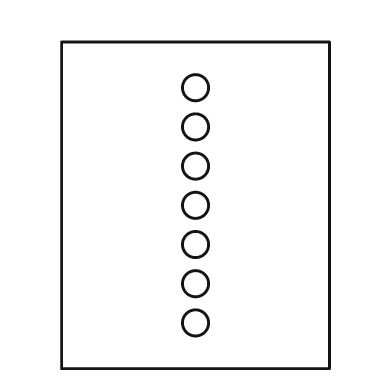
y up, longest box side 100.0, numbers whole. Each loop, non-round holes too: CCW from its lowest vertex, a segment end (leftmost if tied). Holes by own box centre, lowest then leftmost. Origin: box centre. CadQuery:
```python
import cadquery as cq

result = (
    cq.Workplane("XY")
    .moveTo(-41.0, -50.0)
    .lineTo(41.0, -50.0)
    .lineTo(41.0, 50.0)
    .lineTo(-41.0, 50.0)
    .close()
    .moveTo(0.0, -36.0)
    .circle(4.0)
    .moveTo(0.0, -24.0)
    .circle(4.0)
    .moveTo(0.0, -12.0)
    .circle(4.0)
    .moveTo(0.0, 0.0)
    .circle(4.0)
    .moveTo(0.0, 12.0)
    .circle(4.0)
    .moveTo(0.0, 24.0)
    .circle(4.0)
    .moveTo(0.0, 36.0)
    .circle(4.0)
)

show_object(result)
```